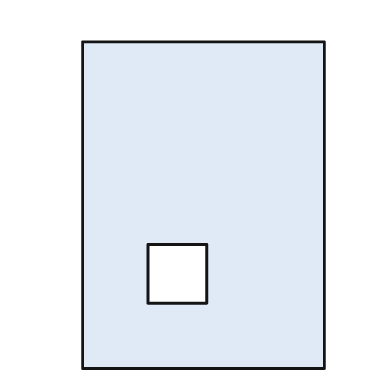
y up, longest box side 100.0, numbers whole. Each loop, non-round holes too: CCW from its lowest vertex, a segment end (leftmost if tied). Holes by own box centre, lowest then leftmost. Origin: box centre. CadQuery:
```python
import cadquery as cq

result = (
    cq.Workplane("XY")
    .moveTo(-37.0, -50.0)
    .lineTo(37.0, -50.0)
    .lineTo(37.0, 50.0)
    .lineTo(-37.0, 50.0)
    .close()
    .moveTo(-17.0, -30.0)
    .lineTo(1.0, -30.0)
    .lineTo(1.0, -12.0)
    .lineTo(-17.0, -12.0)
    .close()
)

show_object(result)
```